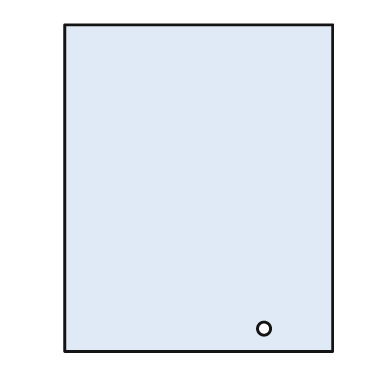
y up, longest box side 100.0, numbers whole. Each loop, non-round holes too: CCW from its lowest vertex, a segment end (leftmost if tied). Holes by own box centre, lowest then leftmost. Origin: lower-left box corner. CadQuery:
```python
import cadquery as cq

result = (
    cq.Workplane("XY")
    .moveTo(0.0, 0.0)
    .lineTo(82.0, 0.0)
    .lineTo(82.0, 100.0)
    .lineTo(0.0, 100.0)
    .close()
    .moveTo(61.0, 7.0)
    .circle(2.0)
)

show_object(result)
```